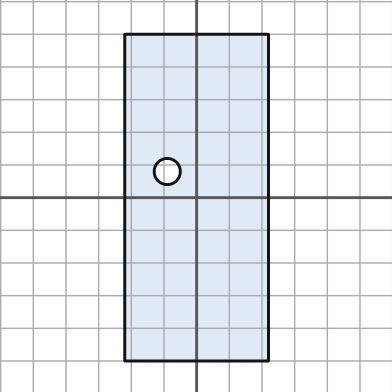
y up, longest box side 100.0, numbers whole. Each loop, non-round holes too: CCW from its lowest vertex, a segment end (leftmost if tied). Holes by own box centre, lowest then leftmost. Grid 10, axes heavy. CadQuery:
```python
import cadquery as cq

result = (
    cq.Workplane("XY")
    .moveTo(-22.0, -50.0)
    .lineTo(22.0, -50.0)
    .lineTo(22.0, 50.0)
    .lineTo(-22.0, 50.0)
    .close()
    .moveTo(-9.0, 8.0)
    .circle(4.0)
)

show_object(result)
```